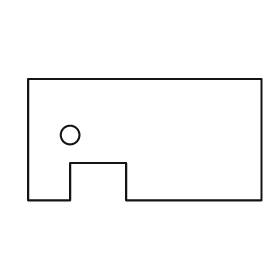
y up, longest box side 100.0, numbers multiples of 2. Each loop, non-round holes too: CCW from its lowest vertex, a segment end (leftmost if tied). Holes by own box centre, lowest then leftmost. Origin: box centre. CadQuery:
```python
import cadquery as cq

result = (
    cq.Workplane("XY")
    .moveTo(-50.0, -26.0)
    .lineTo(-32.0, -26.0)
    .lineTo(-32.0, -10.0)
    .lineTo(-8.0, -10.0)
    .lineTo(-8.0, -26.0)
    .lineTo(50.0, -26.0)
    .lineTo(50.0, 26.0)
    .lineTo(-50.0, 26.0)
    .close()
    .moveTo(-32.0, 2.0)
    .circle(4.0)
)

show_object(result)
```